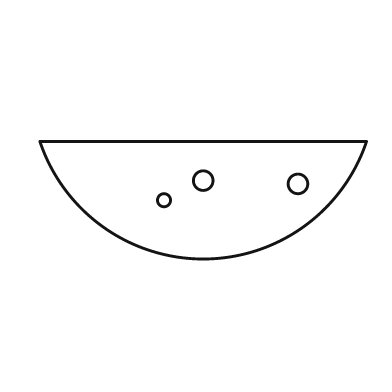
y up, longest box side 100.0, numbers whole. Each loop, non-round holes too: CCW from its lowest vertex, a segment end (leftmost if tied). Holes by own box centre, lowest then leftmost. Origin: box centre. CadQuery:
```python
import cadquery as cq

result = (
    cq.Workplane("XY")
    .moveTo(-50.0, 18.0)
    .threePointArc((0.0, -18.0), (50.0, 18.0))
    .close()
    .moveTo(-12.0, 0.0)
    .circle(2.0)
    .moveTo(29.0, 5.0)
    .circle(3.0)
    .moveTo(0.0, 6.0)
    .circle(3.0)
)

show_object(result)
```